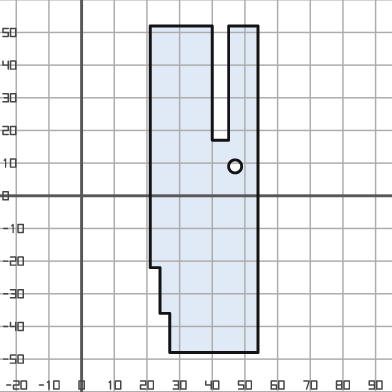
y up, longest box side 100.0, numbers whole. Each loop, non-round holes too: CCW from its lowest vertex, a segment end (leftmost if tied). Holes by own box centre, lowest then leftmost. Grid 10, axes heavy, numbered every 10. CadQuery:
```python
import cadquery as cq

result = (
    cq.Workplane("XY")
    .moveTo(27.0, -48.0)
    .lineTo(54.0, -48.0)
    .lineTo(54.0, 52.0)
    .lineTo(45.0, 52.0)
    .lineTo(45.0, 17.0)
    .lineTo(40.0, 17.0)
    .lineTo(40.0, 52.0)
    .lineTo(21.0, 52.0)
    .lineTo(21.0, -22.0)
    .lineTo(24.0, -22.0)
    .lineTo(24.0, -36.0)
    .lineTo(27.0, -36.0)
    .close()
    .moveTo(47.0, 9.0)
    .circle(2.0)
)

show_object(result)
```